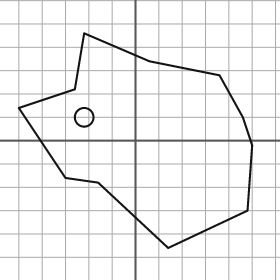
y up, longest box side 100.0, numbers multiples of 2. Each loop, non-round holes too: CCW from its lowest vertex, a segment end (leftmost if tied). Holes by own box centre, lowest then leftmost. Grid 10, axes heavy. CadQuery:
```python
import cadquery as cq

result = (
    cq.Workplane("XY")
    .moveTo(14.0, -46.0)
    .lineTo(48.0, -30.0)
    .lineTo(50.0, -2.0)
    .lineTo(46.0, 10.0)
    .lineTo(36.0, 28.0)
    .lineTo(6.0, 34.0)
    .lineTo(-22.0, 46.0)
    .lineTo(-26.0, 22.0)
    .lineTo(-50.0, 14.0)
    .lineTo(-30.0, -16.0)
    .lineTo(-16.0, -18.0)
    .close()
    .moveTo(-22.0, 10.0)
    .circle(4.0)
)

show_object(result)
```